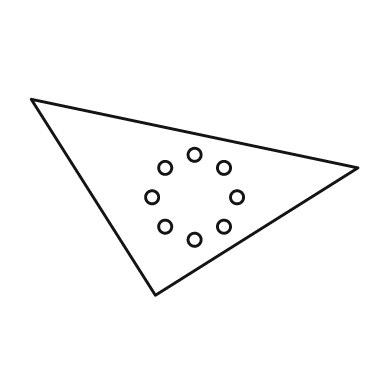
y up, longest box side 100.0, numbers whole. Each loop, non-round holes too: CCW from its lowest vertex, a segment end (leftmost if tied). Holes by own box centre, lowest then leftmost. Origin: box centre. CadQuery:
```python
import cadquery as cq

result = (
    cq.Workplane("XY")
    .moveTo(-12.0, -30.0)
    .lineTo(50.0, 9.0)
    .lineTo(-50.0, 30.0)
    .close()
    .moveTo(0.0, -13.0)
    .circle(2.0)
    .moveTo(-9.0, -9.0)
    .circle(2.0)
    .moveTo(9.0, -9.0)
    .circle(2.0)
    .moveTo(-13.0, 0.0)
    .circle(2.0)
    .moveTo(13.0, 0.0)
    .circle(2.0)
    .moveTo(-9.0, 9.0)
    .circle(2.0)
    .moveTo(9.0, 9.0)
    .circle(2.0)
    .moveTo(0.0, 13.0)
    .circle(2.0)
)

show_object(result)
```